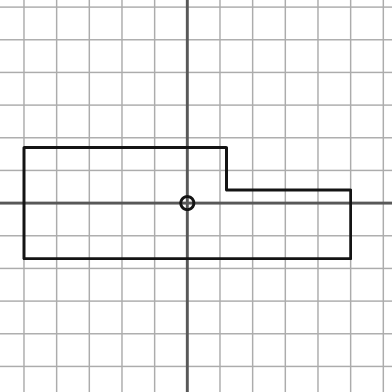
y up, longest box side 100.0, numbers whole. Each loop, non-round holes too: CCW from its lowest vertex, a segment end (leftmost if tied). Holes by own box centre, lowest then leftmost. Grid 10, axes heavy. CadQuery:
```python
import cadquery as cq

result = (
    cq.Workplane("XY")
    .moveTo(-50.0, -17.0)
    .lineTo(50.0, -17.0)
    .lineTo(50.0, 4.0)
    .lineTo(12.0, 4.0)
    .lineTo(12.0, 17.0)
    .lineTo(-50.0, 17.0)
    .close()
    .moveTo(0.0, 0.0)
    .circle(2.0)
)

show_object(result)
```